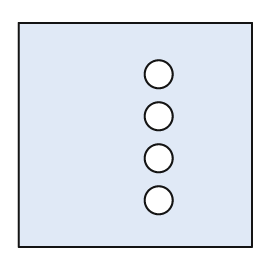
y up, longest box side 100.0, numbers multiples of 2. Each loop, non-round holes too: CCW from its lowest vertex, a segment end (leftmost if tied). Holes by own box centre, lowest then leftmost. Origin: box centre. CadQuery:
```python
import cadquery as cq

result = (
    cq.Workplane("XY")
    .moveTo(-50.0, -48.0)
    .lineTo(50.0, -48.0)
    .lineTo(50.0, 48.0)
    .lineTo(-50.0, 48.0)
    .close()
    .moveTo(10.0, -28.0)
    .circle(6.0)
    .moveTo(10.0, -10.0)
    .circle(6.0)
    .moveTo(10.0, 8.0)
    .circle(6.0)
    .moveTo(10.0, 26.0)
    .circle(6.0)
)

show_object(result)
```